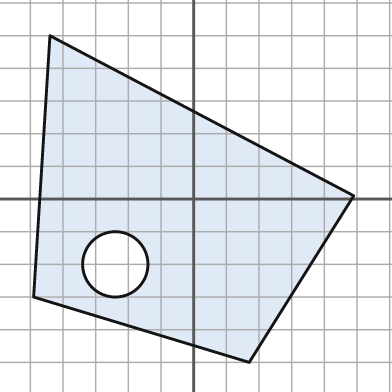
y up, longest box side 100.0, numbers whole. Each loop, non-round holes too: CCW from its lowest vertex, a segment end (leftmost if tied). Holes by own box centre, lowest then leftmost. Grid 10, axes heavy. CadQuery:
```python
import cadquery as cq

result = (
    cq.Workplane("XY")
    .moveTo(17.0, -50.0)
    .lineTo(49.0, 1.0)
    .lineTo(-44.0, 50.0)
    .lineTo(-49.0, -30.0)
    .close()
    .moveTo(-24.0, -20.0)
    .circle(10.0)
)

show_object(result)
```